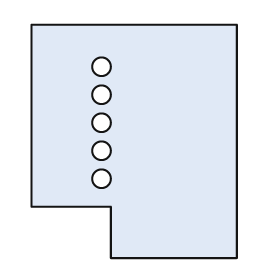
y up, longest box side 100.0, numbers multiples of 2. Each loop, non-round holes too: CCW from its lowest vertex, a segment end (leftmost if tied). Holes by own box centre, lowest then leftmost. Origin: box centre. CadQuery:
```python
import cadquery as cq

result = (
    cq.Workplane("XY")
    .moveTo(-10.0, -50.0)
    .lineTo(44.0, -50.0)
    .lineTo(44.0, 50.0)
    .lineTo(-44.0, 50.0)
    .lineTo(-44.0, -28.0)
    .lineTo(-10.0, -28.0)
    .close()
    .moveTo(-14.0, -16.0)
    .circle(4.0)
    .moveTo(-14.0, -4.0)
    .circle(4.0)
    .moveTo(-14.0, 8.0)
    .circle(4.0)
    .moveTo(-14.0, 20.0)
    .circle(4.0)
    .moveTo(-14.0, 32.0)
    .circle(4.0)
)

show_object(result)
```